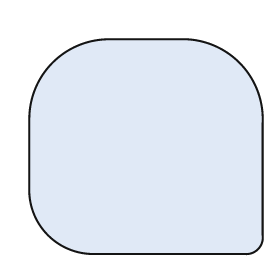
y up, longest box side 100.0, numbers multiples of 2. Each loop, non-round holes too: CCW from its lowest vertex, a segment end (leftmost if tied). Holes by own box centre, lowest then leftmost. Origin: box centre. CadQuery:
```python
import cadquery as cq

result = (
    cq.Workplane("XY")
    .moveTo(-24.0, -46.0)
    .lineTo(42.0, -46.0)
    .threePointArc((48.0, -44.0), (50.0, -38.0))
    .lineTo(50.0, 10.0)
    .threePointArc((40.0, 36.0), (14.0, 46.0))
    .lineTo(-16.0, 46.0)
    .threePointArc((-40.0, 36.0), (-50.0, 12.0))
    .lineTo(-50.0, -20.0)
    .threePointArc((-42.0, -38.0), (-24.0, -46.0))
    .close()
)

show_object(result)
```